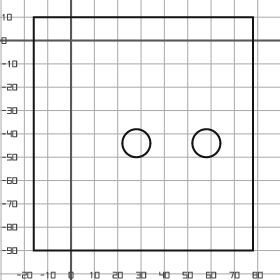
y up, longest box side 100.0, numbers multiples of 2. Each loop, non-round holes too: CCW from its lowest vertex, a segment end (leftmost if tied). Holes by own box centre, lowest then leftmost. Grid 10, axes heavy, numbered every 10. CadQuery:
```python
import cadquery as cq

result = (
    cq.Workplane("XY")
    .moveTo(-16.0, -90.0)
    .lineTo(78.0, -90.0)
    .lineTo(78.0, 10.0)
    .lineTo(-16.0, 10.0)
    .close()
    .moveTo(28.0, -44.0)
    .circle(6.0)
    .moveTo(58.0, -44.0)
    .circle(6.0)
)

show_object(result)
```